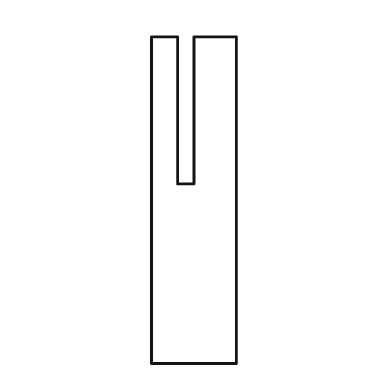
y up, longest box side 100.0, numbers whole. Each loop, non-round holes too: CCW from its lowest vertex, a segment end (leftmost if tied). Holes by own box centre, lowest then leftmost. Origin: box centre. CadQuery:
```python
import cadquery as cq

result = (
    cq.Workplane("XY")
    .moveTo(-13.0, -50.0)
    .lineTo(13.0, -50.0)
    .lineTo(13.0, 50.0)
    .lineTo(0.0, 50.0)
    .lineTo(0.0, 5.0)
    .lineTo(-5.0, 5.0)
    .lineTo(-5.0, 50.0)
    .lineTo(-13.0, 50.0)
    .close()
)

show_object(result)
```